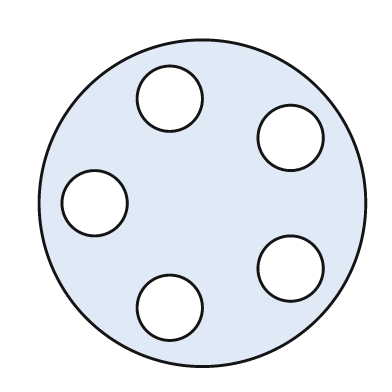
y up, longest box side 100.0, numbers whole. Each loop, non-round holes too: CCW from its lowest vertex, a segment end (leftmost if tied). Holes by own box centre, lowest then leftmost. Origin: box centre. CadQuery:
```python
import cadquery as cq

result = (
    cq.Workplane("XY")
    .moveTo(0.0, 0.0)
    .circle(50.0)
    .moveTo(-10.0, -32.0)
    .circle(10.0)
    .moveTo(27.0, -20.0)
    .circle(10.0)
    .moveTo(-33.0, 0.0)
    .circle(10.0)
    .moveTo(27.0, 20.0)
    .circle(10.0)
    .moveTo(-10.0, 32.0)
    .circle(10.0)
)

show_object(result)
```